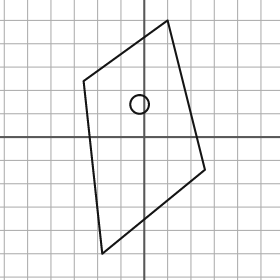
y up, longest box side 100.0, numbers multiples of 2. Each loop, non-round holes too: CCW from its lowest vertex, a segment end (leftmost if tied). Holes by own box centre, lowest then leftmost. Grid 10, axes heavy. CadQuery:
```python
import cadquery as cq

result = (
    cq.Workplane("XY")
    .moveTo(-18.0, -50.0)
    .lineTo(26.0, -14.0)
    .lineTo(10.0, 50.0)
    .lineTo(-26.0, 24.0)
    .close()
    .moveTo(-2.0, 14.0)
    .circle(4.0)
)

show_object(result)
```